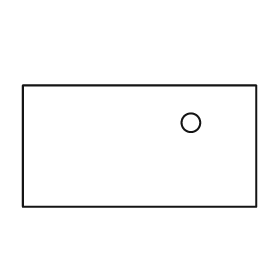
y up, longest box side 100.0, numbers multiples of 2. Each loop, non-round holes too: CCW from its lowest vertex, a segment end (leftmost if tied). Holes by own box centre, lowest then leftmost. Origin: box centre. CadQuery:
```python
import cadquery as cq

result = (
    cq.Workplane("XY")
    .moveTo(-50.0, -26.0)
    .lineTo(50.0, -26.0)
    .lineTo(50.0, 26.0)
    .lineTo(-50.0, 26.0)
    .close()
    .moveTo(22.0, 10.0)
    .circle(4.0)
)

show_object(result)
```